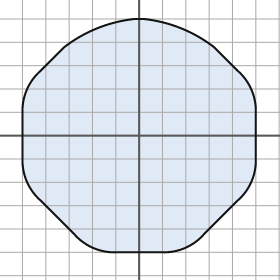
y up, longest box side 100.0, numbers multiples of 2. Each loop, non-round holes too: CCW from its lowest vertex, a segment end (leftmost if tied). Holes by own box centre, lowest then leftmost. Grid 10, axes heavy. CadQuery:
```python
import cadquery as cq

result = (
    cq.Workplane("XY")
    .moveTo(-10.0, -50.0)
    .lineTo(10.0, -50.0)
    .threePointArc((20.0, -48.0), (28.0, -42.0))
    .lineTo(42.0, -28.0)
    .threePointArc((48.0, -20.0), (50.0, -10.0))
    .lineTo(50.0, 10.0)
    .threePointArc((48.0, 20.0), (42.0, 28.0))
    .lineTo(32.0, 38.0)
    .threePointArc((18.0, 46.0), (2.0, 50.0))
    .lineTo(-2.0, 50.0)
    .threePointArc((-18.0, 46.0), (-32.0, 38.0))
    .lineTo(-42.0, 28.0)
    .threePointArc((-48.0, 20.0), (-50.0, 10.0))
    .lineTo(-50.0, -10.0)
    .threePointArc((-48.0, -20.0), (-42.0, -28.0))
    .lineTo(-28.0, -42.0)
    .threePointArc((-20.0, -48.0), (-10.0, -50.0))
    .close()
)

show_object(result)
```